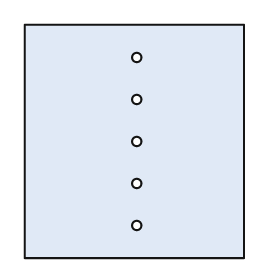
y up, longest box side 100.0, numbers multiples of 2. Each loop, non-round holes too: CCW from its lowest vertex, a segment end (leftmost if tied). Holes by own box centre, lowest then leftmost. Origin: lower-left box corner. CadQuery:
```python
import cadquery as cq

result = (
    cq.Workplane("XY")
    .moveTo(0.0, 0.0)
    .lineTo(94.0, 0.0)
    .lineTo(94.0, 100.0)
    .lineTo(0.0, 100.0)
    .close()
    .moveTo(48.0, 14.0)
    .circle(2.0)
    .moveTo(48.0, 32.0)
    .circle(2.0)
    .moveTo(48.0, 50.0)
    .circle(2.0)
    .moveTo(48.0, 68.0)
    .circle(2.0)
    .moveTo(48.0, 86.0)
    .circle(2.0)
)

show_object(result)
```